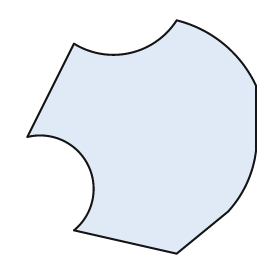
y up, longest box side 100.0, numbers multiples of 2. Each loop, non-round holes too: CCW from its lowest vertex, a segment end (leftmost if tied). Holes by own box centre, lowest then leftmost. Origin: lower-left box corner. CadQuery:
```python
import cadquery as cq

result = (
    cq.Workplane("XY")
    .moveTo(64.0, 0.0)
    .lineTo(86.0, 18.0)
    .threePointArc((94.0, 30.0), (98.0, 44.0))
    .lineTo(98.0, 72.0)
    .threePointArc((84.0, 90.0), (64.0, 100.0))
    .threePointArc((44.0, 86.0), (20.0, 90.0))
    .lineTo(0.0, 50.0)
    .threePointArc((26.0, 38.0), (20.0, 10.0))
    .close()
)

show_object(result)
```